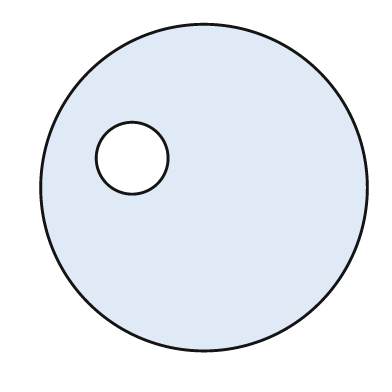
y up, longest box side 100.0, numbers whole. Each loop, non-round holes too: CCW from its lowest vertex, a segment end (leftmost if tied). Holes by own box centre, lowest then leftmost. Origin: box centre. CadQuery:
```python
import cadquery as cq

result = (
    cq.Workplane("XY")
    .moveTo(0.0, 0.0)
    .circle(50.0)
    .moveTo(-22.0, 9.0)
    .circle(11.0)
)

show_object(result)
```